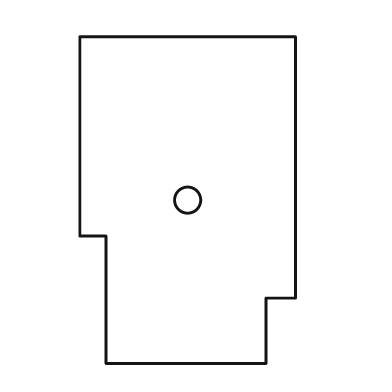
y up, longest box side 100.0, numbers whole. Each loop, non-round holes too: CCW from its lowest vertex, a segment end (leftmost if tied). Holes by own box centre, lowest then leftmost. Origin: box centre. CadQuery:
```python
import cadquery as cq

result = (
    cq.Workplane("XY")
    .moveTo(-25.0, -50.0)
    .lineTo(24.0, -50.0)
    .lineTo(24.0, -30.0)
    .lineTo(33.0, -30.0)
    .lineTo(33.0, 50.0)
    .lineTo(-33.0, 50.0)
    .lineTo(-33.0, -11.0)
    .lineTo(-25.0, -11.0)
    .close()
    .moveTo(0.0, 0.0)
    .circle(4.0)
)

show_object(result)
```